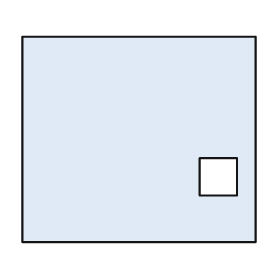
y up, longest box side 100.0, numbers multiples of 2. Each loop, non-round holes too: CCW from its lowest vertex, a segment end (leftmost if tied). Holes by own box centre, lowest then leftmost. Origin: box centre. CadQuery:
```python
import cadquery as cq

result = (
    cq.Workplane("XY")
    .moveTo(-50.0, -44.0)
    .lineTo(50.0, -44.0)
    .lineTo(50.0, 44.0)
    .lineTo(-50.0, 44.0)
    .close()
    .moveTo(26.0, -24.0)
    .lineTo(42.0, -24.0)
    .lineTo(42.0, -8.0)
    .lineTo(26.0, -8.0)
    .close()
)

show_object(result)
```